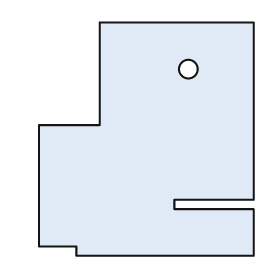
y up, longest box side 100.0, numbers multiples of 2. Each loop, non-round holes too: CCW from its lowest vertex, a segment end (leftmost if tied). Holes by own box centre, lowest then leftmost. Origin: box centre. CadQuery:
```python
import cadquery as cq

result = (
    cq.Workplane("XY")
    .moveTo(-30.0, -50.0)
    .lineTo(46.0, -50.0)
    .lineTo(46.0, -30.0)
    .lineTo(12.0, -30.0)
    .lineTo(12.0, -26.0)
    .lineTo(46.0, -26.0)
    .lineTo(46.0, 50.0)
    .lineTo(-20.0, 50.0)
    .lineTo(-20.0, 6.0)
    .lineTo(-46.0, 6.0)
    .lineTo(-46.0, -46.0)
    .lineTo(-30.0, -46.0)
    .close()
    .moveTo(18.0, 30.0)
    .circle(4.0)
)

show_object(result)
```